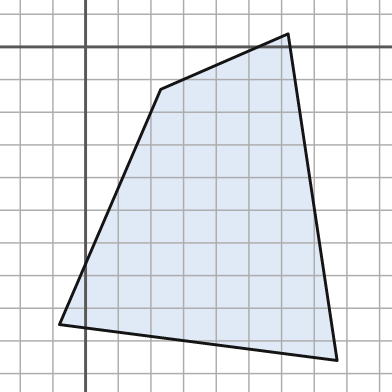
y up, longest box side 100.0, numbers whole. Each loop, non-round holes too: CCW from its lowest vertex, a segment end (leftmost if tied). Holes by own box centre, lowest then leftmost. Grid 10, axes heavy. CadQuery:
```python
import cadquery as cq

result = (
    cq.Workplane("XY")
    .moveTo(77.0, -96.0)
    .lineTo(62.0, 4.0)
    .lineTo(23.0, -13.0)
    .lineTo(-8.0, -85.0)
    .close()
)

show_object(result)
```